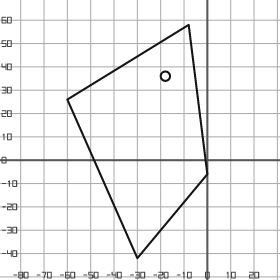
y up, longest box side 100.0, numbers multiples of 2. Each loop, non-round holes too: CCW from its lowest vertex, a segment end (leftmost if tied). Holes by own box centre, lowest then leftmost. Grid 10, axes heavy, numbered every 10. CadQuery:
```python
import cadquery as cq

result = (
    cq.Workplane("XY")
    .moveTo(-30.0, -42.0)
    .lineTo(0.0, -6.0)
    .lineTo(-8.0, 58.0)
    .lineTo(-60.0, 26.0)
    .close()
    .moveTo(-18.0, 36.0)
    .circle(2.0)
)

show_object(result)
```